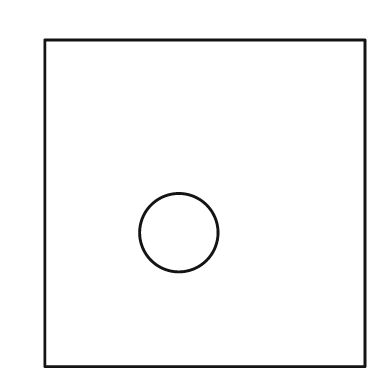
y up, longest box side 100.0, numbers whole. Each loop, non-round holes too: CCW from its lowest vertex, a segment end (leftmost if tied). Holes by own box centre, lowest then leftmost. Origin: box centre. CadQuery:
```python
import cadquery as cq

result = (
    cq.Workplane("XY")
    .moveTo(-49.0, -50.0)
    .lineTo(49.0, -50.0)
    .lineTo(49.0, 50.0)
    .lineTo(-49.0, 50.0)
    .close()
    .moveTo(-8.0, -9.0)
    .circle(12.0)
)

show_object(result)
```